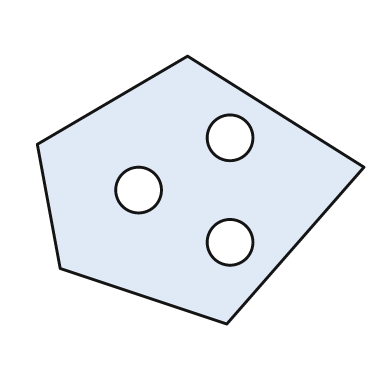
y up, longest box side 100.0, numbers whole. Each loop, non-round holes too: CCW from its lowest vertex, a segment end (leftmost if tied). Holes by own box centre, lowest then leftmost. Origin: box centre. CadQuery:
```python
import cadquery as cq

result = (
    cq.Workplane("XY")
    .moveTo(8.0, -41.0)
    .lineTo(50.0, 7.0)
    .lineTo(-4.0, 41.0)
    .lineTo(-50.0, 14.0)
    .lineTo(-43.0, -24.0)
    .close()
    .moveTo(9.0, -16.0)
    .circle(7.0)
    .moveTo(-19.0, 0.0)
    .circle(7.0)
    .moveTo(9.0, 16.0)
    .circle(7.0)
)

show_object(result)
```